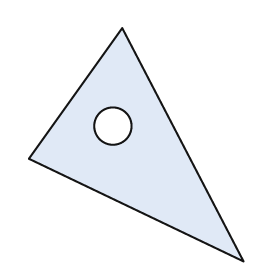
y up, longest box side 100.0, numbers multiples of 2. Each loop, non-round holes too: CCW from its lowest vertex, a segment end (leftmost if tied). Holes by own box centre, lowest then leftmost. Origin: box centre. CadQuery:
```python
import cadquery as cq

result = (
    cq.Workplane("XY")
    .moveTo(46.0, -50.0)
    .lineTo(-6.0, 50.0)
    .lineTo(-46.0, -6.0)
    .close()
    .moveTo(-10.0, 8.0)
    .circle(8.0)
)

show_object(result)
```